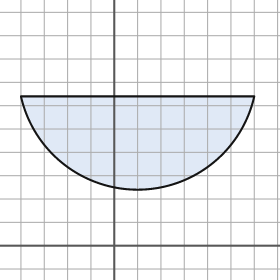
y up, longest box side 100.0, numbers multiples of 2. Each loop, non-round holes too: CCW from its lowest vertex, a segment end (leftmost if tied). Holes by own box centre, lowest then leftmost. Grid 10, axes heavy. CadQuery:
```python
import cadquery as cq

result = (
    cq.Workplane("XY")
    .moveTo(-40.0, 64.0)
    .threePointArc((10.0, 24.0), (60.0, 64.0))
    .close()
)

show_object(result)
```